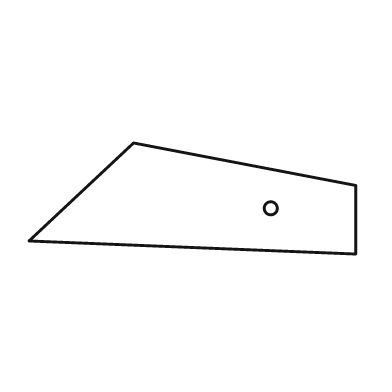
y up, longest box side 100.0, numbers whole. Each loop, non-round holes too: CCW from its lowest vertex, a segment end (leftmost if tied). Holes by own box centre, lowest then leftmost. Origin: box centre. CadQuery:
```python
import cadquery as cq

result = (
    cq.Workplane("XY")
    .moveTo(50.0, -17.0)
    .lineTo(50.0, 4.0)
    .lineTo(-18.0, 17.0)
    .lineTo(-50.0, -13.0)
    .close()
    .moveTo(24.0, -3.0)
    .circle(2.0)
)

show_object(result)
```